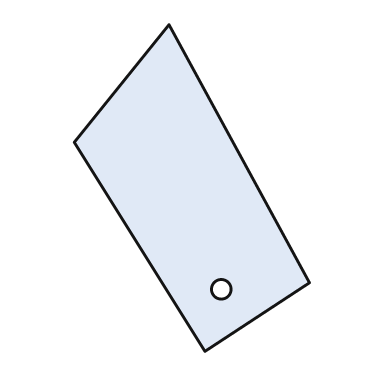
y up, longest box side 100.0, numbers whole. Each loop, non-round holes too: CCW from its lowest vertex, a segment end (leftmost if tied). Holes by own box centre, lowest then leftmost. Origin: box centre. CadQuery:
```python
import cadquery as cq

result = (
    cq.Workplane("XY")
    .moveTo(4.0, -50.0)
    .lineTo(36.0, -29.0)
    .lineTo(-7.0, 50.0)
    .lineTo(-36.0, 14.0)
    .close()
    .moveTo(9.0, -31.0)
    .circle(3.0)
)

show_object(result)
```